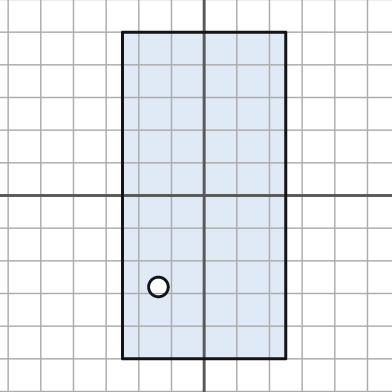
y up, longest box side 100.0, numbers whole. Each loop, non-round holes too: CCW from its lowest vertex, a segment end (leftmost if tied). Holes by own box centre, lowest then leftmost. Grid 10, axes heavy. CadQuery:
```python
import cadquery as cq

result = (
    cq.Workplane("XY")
    .moveTo(-25.0, -50.0)
    .lineTo(25.0, -50.0)
    .lineTo(25.0, 50.0)
    .lineTo(-25.0, 50.0)
    .close()
    .moveTo(-14.0, -28.0)
    .circle(3.0)
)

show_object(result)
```